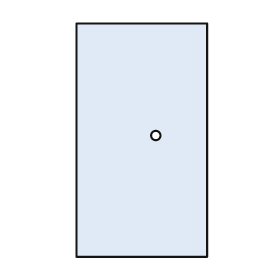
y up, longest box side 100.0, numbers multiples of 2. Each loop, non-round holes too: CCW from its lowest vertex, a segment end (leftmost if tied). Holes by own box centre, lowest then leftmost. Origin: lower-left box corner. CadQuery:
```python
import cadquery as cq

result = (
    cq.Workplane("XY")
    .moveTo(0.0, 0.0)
    .lineTo(56.0, 0.0)
    .lineTo(56.0, 100.0)
    .lineTo(0.0, 100.0)
    .close()
    .moveTo(34.0, 52.0)
    .circle(2.0)
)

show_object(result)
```